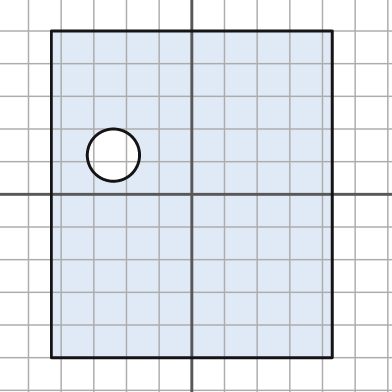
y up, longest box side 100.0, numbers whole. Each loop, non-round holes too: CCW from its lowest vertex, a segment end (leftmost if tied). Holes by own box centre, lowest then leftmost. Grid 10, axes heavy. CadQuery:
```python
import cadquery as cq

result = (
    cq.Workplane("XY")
    .moveTo(-43.0, -50.0)
    .lineTo(43.0, -50.0)
    .lineTo(43.0, 50.0)
    .lineTo(-43.0, 50.0)
    .close()
    .moveTo(-24.0, 12.0)
    .circle(8.0)
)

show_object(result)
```